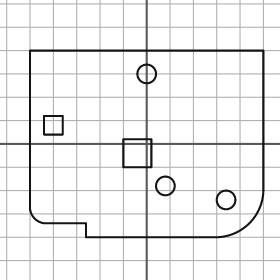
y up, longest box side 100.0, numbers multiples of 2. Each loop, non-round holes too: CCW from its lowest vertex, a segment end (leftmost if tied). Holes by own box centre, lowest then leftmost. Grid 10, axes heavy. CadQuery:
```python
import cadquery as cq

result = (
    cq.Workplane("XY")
    .moveTo(-26.0, -40.0)
    .lineTo(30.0, -40.0)
    .threePointArc((44.0, -34.0), (50.0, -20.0))
    .lineTo(50.0, 40.0)
    .lineTo(-50.0, 40.0)
    .lineTo(-50.0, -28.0)
    .threePointArc((-48.0, -32.0), (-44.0, -34.0))
    .lineTo(-26.0, -34.0)
    .close()
    .moveTo(34.0, -24.0)
    .circle(4.0)
    .moveTo(8.0, -18.0)
    .circle(4.0)
    .moveTo(-10.0, -10.0)
    .lineTo(2.0, -10.0)
    .lineTo(2.0, 2.0)
    .lineTo(-10.0, 2.0)
    .close()
    .moveTo(-44.0, 4.0)
    .lineTo(-36.0, 4.0)
    .lineTo(-36.0, 12.0)
    .lineTo(-44.0, 12.0)
    .close()
    .moveTo(0.0, 30.0)
    .circle(4.0)
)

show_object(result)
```